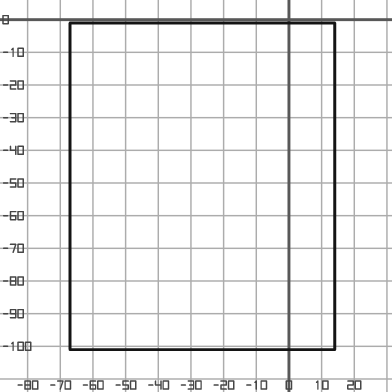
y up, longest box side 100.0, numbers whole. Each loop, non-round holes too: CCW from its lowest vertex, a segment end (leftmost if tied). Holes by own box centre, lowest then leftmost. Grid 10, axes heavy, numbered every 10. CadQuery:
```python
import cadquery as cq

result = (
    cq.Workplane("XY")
    .moveTo(-67.0, -101.0)
    .lineTo(14.0, -101.0)
    .lineTo(14.0, -1.0)
    .lineTo(-67.0, -1.0)
    .close()
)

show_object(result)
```